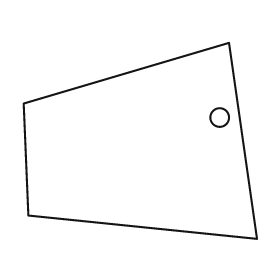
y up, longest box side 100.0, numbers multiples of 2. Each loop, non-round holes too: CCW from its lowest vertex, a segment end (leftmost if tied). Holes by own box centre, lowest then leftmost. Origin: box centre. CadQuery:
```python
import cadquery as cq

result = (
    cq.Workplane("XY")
    .moveTo(50.0, -42.0)
    .lineTo(38.0, 42.0)
    .lineTo(-50.0, 16.0)
    .lineTo(-48.0, -32.0)
    .close()
    .moveTo(34.0, 10.0)
    .circle(4.0)
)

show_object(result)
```